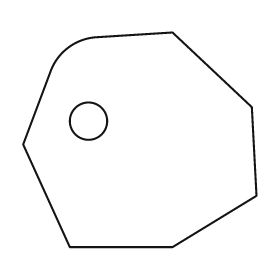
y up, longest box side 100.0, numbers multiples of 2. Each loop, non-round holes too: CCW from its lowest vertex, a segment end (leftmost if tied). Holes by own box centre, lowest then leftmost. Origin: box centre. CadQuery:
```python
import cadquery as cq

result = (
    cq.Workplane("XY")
    .moveTo(-30.0, -46.0)
    .lineTo(14.0, -46.0)
    .lineTo(50.0, -24.0)
    .lineTo(48.0, 14.0)
    .lineTo(14.0, 46.0)
    .lineTo(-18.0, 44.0)
    .threePointArc((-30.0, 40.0), (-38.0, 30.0))
    .lineTo(-50.0, -2.0)
    .close()
    .moveTo(-22.0, 8.0)
    .circle(8.0)
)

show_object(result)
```